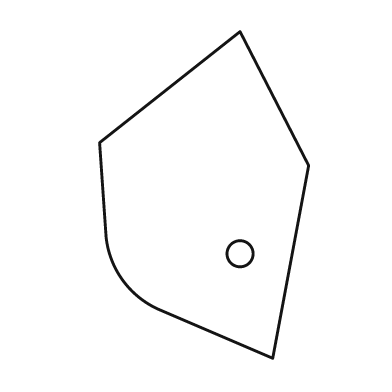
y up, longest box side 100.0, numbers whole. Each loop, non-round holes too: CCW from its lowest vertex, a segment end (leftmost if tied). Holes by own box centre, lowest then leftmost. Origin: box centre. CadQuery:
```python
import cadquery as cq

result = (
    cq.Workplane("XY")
    .moveTo(21.0, -50.0)
    .lineTo(32.0, 9.0)
    .lineTo(11.0, 50.0)
    .lineTo(-32.0, 16.0)
    .lineTo(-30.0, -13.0)
    .threePointArc((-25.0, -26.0), (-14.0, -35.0))
    .close()
    .moveTo(11.0, -18.0)
    .circle(4.0)
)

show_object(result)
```